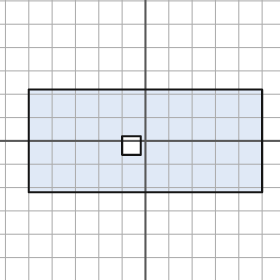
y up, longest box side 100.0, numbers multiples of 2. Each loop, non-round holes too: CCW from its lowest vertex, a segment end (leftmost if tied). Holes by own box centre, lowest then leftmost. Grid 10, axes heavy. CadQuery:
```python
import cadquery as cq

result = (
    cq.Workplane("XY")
    .moveTo(-50.0, -22.0)
    .lineTo(50.0, -22.0)
    .lineTo(50.0, 22.0)
    .lineTo(-50.0, 22.0)
    .close()
    .moveTo(-10.0, -6.0)
    .lineTo(-2.0, -6.0)
    .lineTo(-2.0, 2.0)
    .lineTo(-10.0, 2.0)
    .close()
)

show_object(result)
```